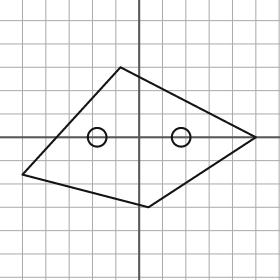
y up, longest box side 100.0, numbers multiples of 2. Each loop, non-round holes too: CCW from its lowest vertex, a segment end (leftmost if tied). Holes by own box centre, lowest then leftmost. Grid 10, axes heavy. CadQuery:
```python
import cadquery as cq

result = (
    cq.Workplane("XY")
    .moveTo(4.0, -30.0)
    .lineTo(50.0, 0.0)
    .lineTo(-8.0, 30.0)
    .lineTo(-50.0, -16.0)
    .close()
    .moveTo(-18.0, 0.0)
    .circle(4.0)
    .moveTo(18.0, 0.0)
    .circle(4.0)
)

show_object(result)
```